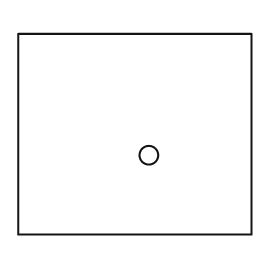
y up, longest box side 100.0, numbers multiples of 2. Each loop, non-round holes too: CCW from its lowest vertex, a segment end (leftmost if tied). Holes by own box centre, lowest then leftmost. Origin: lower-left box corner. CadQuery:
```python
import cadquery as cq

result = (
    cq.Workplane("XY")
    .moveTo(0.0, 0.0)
    .lineTo(100.0, 0.0)
    .lineTo(100.0, 86.0)
    .lineTo(0.0, 86.0)
    .close()
    .moveTo(56.0, 34.0)
    .circle(4.0)
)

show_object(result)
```